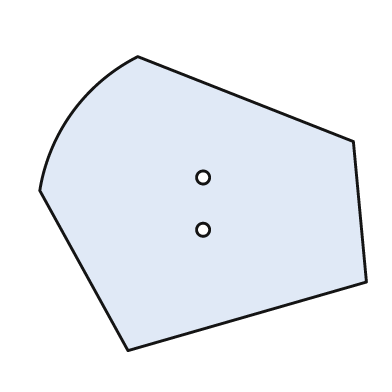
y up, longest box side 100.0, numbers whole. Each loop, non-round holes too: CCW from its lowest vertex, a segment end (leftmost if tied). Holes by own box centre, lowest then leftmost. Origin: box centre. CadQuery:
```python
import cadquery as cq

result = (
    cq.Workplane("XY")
    .moveTo(-23.0, -45.0)
    .lineTo(50.0, -24.0)
    .lineTo(46.0, 19.0)
    .lineTo(-20.0, 45.0)
    .threePointArc((-40.0, 28.0), (-50.0, 4.0))
    .close()
    .moveTo(0.0, -8.0)
    .circle(2.0)
    .moveTo(0.0, 8.0)
    .circle(2.0)
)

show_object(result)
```